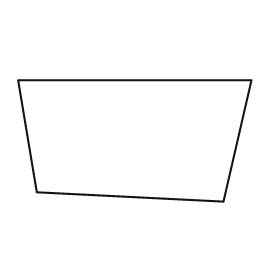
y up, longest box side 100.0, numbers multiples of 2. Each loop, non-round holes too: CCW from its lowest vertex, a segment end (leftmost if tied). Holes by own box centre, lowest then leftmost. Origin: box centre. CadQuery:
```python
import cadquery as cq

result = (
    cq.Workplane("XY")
    .moveTo(38.0, -26.0)
    .lineTo(50.0, 26.0)
    .lineTo(-50.0, 26.0)
    .lineTo(-42.0, -22.0)
    .close()
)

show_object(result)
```